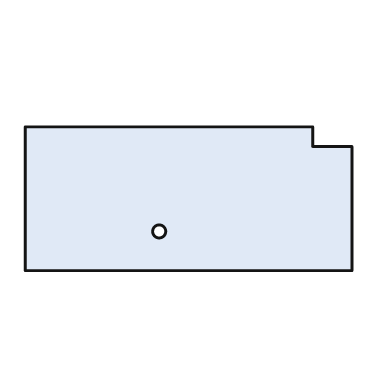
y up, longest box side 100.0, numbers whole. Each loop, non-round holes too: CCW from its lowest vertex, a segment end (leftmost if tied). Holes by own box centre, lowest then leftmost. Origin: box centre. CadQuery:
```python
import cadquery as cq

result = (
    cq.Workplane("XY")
    .moveTo(-50.0, -22.0)
    .lineTo(50.0, -22.0)
    .lineTo(50.0, 16.0)
    .lineTo(38.0, 16.0)
    .lineTo(38.0, 22.0)
    .lineTo(-50.0, 22.0)
    .close()
    .moveTo(-9.0, -10.0)
    .circle(2.0)
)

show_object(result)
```